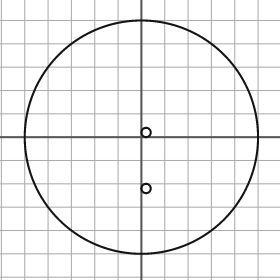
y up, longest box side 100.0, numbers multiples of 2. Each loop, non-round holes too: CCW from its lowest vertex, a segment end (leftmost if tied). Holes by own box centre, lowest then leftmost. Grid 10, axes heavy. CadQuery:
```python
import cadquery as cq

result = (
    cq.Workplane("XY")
    .moveTo(0.0, 0.0)
    .circle(50.0)
    .moveTo(2.0, -22.0)
    .circle(2.0)
    .moveTo(2.0, 2.0)
    .circle(2.0)
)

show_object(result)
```